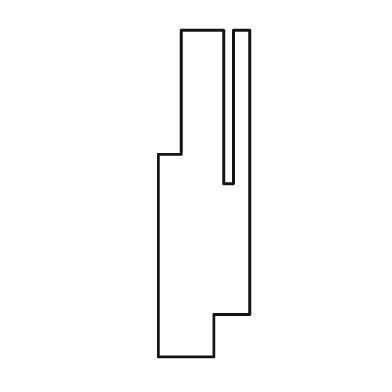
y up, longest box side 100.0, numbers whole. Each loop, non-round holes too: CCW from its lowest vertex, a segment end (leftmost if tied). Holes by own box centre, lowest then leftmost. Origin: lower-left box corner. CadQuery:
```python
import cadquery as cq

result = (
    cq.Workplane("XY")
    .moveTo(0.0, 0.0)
    .lineTo(17.0, 0.0)
    .lineTo(17.0, 13.0)
    .lineTo(28.0, 13.0)
    .lineTo(28.0, 100.0)
    .lineTo(23.0, 100.0)
    .lineTo(23.0, 53.0)
    .lineTo(20.0, 53.0)
    .lineTo(20.0, 100.0)
    .lineTo(7.0, 100.0)
    .lineTo(7.0, 62.0)
    .lineTo(0.0, 62.0)
    .close()
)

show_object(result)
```